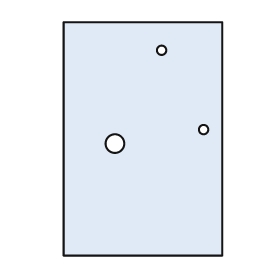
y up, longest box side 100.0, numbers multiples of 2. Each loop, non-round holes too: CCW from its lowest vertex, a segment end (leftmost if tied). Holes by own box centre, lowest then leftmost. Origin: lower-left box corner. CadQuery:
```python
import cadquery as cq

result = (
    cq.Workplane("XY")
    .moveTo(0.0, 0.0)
    .lineTo(68.0, 0.0)
    .lineTo(68.0, 100.0)
    .lineTo(0.0, 100.0)
    .close()
    .moveTo(22.0, 48.0)
    .circle(4.0)
    .moveTo(60.0, 54.0)
    .circle(2.0)
    .moveTo(42.0, 88.0)
    .circle(2.0)
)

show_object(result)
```